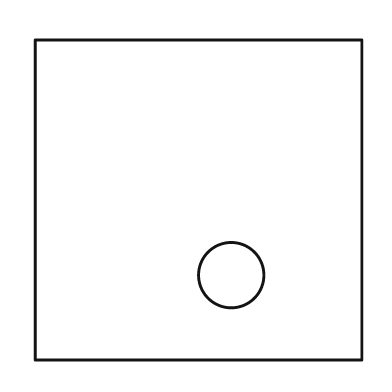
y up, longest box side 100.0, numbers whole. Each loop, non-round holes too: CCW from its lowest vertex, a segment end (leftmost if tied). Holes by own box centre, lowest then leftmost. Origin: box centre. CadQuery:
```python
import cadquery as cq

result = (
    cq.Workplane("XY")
    .moveTo(-50.0, -49.0)
    .lineTo(50.0, -49.0)
    .lineTo(50.0, 49.0)
    .lineTo(-50.0, 49.0)
    .close()
    .moveTo(10.0, -23.0)
    .circle(10.0)
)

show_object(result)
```